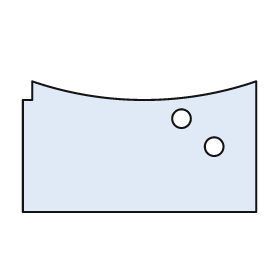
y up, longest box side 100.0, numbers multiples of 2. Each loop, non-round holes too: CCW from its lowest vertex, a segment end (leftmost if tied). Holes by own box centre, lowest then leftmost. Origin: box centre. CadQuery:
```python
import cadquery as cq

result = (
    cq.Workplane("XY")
    .moveTo(-50.0, -28.0)
    .lineTo(50.0, -28.0)
    .lineTo(50.0, 28.0)
    .threePointArc((2.0, 20.0), (-46.0, 28.0))
    .lineTo(-46.0, 20.0)
    .lineTo(-50.0, 20.0)
    .close()
    .moveTo(32.0, 0.0)
    .circle(4.0)
    .moveTo(18.0, 12.0)
    .circle(4.0)
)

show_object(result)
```